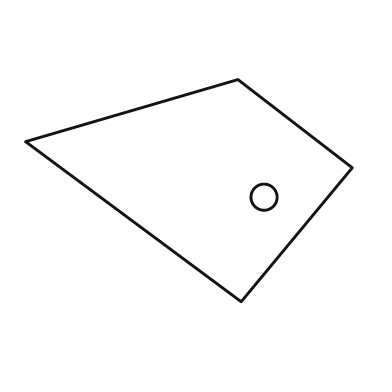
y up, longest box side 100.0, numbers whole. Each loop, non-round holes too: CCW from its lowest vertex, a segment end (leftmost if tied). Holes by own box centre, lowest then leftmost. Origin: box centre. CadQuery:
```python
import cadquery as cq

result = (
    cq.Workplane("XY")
    .moveTo(16.0, -34.0)
    .lineTo(50.0, 7.0)
    .lineTo(15.0, 34.0)
    .lineTo(-50.0, 15.0)
    .close()
    .moveTo(23.0, -2.0)
    .circle(4.0)
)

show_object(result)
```